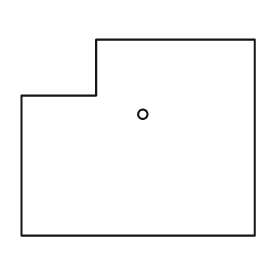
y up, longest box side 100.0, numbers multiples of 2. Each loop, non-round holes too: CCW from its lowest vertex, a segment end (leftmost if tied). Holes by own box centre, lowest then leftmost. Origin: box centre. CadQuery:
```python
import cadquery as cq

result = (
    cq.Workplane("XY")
    .moveTo(-50.0, -42.0)
    .lineTo(50.0, -42.0)
    .lineTo(50.0, 42.0)
    .lineTo(-18.0, 42.0)
    .lineTo(-18.0, 18.0)
    .lineTo(-50.0, 18.0)
    .close()
    .moveTo(2.0, 10.0)
    .circle(2.0)
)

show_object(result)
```